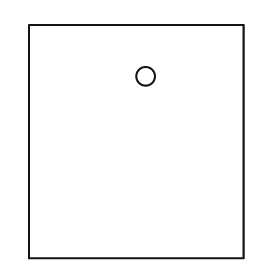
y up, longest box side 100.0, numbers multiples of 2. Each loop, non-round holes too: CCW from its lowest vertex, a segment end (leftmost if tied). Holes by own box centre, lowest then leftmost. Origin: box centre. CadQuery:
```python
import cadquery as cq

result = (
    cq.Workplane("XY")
    .moveTo(-46.0, -50.0)
    .lineTo(46.0, -50.0)
    .lineTo(46.0, 50.0)
    .lineTo(-46.0, 50.0)
    .close()
    .moveTo(4.0, 28.0)
    .circle(4.0)
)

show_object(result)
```